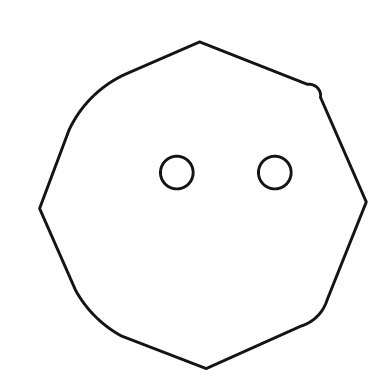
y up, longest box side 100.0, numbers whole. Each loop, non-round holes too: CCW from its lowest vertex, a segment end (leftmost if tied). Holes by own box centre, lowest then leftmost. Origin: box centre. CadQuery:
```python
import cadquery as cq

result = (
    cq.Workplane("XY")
    .moveTo(1.0, -50.0)
    .lineTo(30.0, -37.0)
    .threePointArc((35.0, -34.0), (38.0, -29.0))
    .lineTo(50.0, 1.0)
    .lineTo(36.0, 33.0)
    .threePointArc((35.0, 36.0), (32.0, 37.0))
    .lineTo(-1.0, 50.0)
    .lineTo(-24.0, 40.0)
    .threePointArc((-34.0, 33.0), (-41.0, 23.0))
    .lineTo(-50.0, -1.0)
    .lineTo(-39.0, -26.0)
    .threePointArc((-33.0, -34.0), (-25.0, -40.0))
    .close()
    .moveTo(-8.0, 10.0)
    .circle(5.0)
    .moveTo(22.0, 10.0)
    .circle(5.0)
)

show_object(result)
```